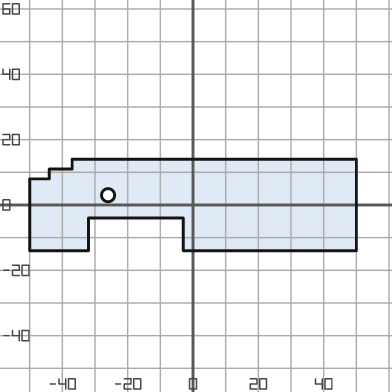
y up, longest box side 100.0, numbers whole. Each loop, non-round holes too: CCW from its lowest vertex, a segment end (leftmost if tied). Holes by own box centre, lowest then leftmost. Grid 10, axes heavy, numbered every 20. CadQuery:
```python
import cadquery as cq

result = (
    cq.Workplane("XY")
    .moveTo(-50.0, -14.0)
    .lineTo(-32.0, -14.0)
    .lineTo(-32.0, -4.0)
    .lineTo(-3.0, -4.0)
    .lineTo(-3.0, -14.0)
    .lineTo(50.0, -14.0)
    .lineTo(50.0, 14.0)
    .lineTo(-37.0, 14.0)
    .lineTo(-37.0, 11.0)
    .lineTo(-44.0, 11.0)
    .lineTo(-44.0, 8.0)
    .lineTo(-50.0, 8.0)
    .close()
    .moveTo(-26.0, 3.0)
    .circle(2.0)
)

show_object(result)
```